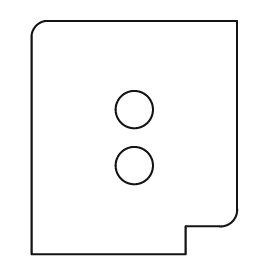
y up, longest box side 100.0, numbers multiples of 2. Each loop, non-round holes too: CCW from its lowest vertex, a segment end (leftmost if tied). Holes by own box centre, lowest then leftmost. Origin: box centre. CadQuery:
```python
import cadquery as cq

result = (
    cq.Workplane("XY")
    .moveTo(-44.0, -50.0)
    .lineTo(22.0, -50.0)
    .lineTo(22.0, -38.0)
    .lineTo(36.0, -38.0)
    .threePointArc((42.0, -36.0), (44.0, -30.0))
    .lineTo(44.0, 50.0)
    .lineTo(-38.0, 50.0)
    .threePointArc((-42.0, 48.0), (-44.0, 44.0))
    .close()
    .moveTo(0.0, -12.0)
    .circle(8.0)
    .moveTo(0.0, 12.0)
    .circle(8.0)
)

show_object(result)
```